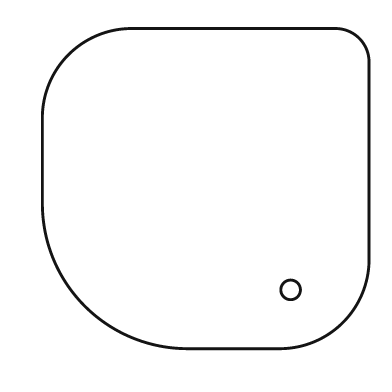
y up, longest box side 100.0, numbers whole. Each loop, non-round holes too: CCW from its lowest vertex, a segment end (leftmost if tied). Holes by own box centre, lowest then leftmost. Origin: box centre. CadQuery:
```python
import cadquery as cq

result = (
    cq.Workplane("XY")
    .moveTo(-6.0, -49.0)
    .lineTo(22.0, -49.0)
    .threePointArc((42.0, -41.0), (50.0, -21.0))
    .lineTo(50.0, 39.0)
    .threePointArc((47.0, 46.0), (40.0, 49.0))
    .lineTo(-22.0, 49.0)
    .threePointArc((-42.0, 41.0), (-50.0, 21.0))
    .lineTo(-50.0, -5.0)
    .threePointArc((-37.0, -36.0), (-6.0, -49.0))
    .close()
    .moveTo(26.0, -31.0)
    .circle(3.0)
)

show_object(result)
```